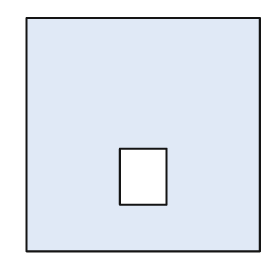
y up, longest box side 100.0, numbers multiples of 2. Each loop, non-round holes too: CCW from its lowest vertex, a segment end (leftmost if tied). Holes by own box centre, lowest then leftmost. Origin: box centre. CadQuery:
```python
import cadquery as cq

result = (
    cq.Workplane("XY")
    .moveTo(-50.0, -50.0)
    .lineTo(50.0, -50.0)
    .lineTo(50.0, 50.0)
    .lineTo(-50.0, 50.0)
    .close()
    .moveTo(-10.0, -30.0)
    .lineTo(10.0, -30.0)
    .lineTo(10.0, -6.0)
    .lineTo(-10.0, -6.0)
    .close()
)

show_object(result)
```